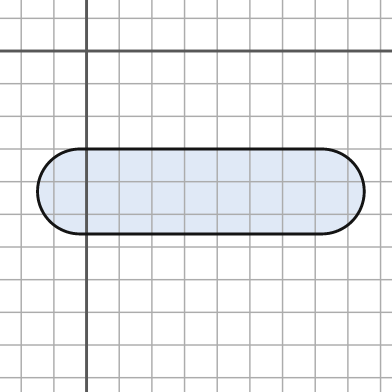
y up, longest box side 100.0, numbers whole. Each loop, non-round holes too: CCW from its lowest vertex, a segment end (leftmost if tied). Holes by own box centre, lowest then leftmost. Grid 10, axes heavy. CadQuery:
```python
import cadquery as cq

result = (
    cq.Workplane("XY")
    .moveTo(-2.0, -56.0)
    .lineTo(72.0, -56.0)
    .threePointArc((85.0, -43.0), (72.0, -30.0))
    .lineTo(-2.0, -30.0)
    .threePointArc((-15.0, -43.0), (-2.0, -56.0))
    .close()
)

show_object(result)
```